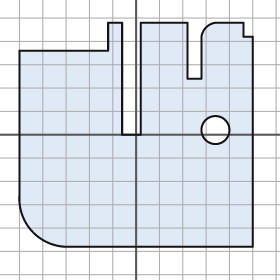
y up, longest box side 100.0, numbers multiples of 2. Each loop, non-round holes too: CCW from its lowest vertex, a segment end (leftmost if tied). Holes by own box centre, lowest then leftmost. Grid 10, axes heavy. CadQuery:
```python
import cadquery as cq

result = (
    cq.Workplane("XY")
    .moveTo(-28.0, -48.0)
    .lineTo(50.0, -48.0)
    .lineTo(50.0, 42.0)
    .lineTo(46.0, 42.0)
    .lineTo(46.0, 48.0)
    .lineTo(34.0, 48.0)
    .threePointArc((30.0, 46.0), (28.0, 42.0))
    .lineTo(28.0, 24.0)
    .lineTo(22.0, 24.0)
    .lineTo(22.0, 48.0)
    .lineTo(2.0, 48.0)
    .lineTo(2.0, 0.0)
    .lineTo(-6.0, 0.0)
    .lineTo(-6.0, 48.0)
    .lineTo(-12.0, 48.0)
    .lineTo(-12.0, 36.0)
    .lineTo(-50.0, 36.0)
    .lineTo(-50.0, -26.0)
    .threePointArc((-44.0, -42.0), (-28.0, -48.0))
    .close()
    .moveTo(34.0, 2.0)
    .circle(6.0)
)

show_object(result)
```